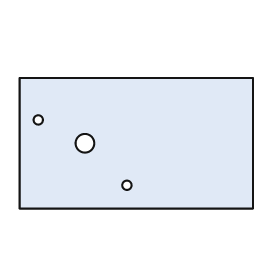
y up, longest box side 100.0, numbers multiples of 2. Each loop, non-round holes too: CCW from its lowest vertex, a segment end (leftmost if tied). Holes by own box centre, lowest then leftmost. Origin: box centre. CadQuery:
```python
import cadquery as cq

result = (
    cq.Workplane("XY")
    .moveTo(-50.0, -28.0)
    .lineTo(50.0, -28.0)
    .lineTo(50.0, 28.0)
    .lineTo(-50.0, 28.0)
    .close()
    .moveTo(-4.0, -18.0)
    .circle(2.0)
    .moveTo(-22.0, 0.0)
    .circle(4.0)
    .moveTo(-42.0, 10.0)
    .circle(2.0)
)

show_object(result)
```